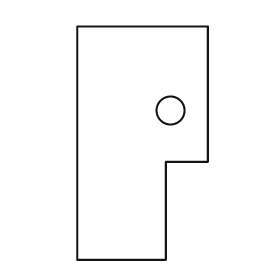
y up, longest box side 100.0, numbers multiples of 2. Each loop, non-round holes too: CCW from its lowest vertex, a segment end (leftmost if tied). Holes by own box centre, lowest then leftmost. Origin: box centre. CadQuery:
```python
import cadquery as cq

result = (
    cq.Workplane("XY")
    .moveTo(-28.0, -50.0)
    .lineTo(10.0, -50.0)
    .lineTo(10.0, -8.0)
    .lineTo(28.0, -8.0)
    .lineTo(28.0, 50.0)
    .lineTo(-28.0, 50.0)
    .close()
    .moveTo(12.0, 14.0)
    .circle(6.0)
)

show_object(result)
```